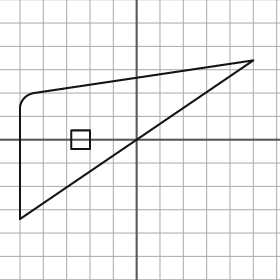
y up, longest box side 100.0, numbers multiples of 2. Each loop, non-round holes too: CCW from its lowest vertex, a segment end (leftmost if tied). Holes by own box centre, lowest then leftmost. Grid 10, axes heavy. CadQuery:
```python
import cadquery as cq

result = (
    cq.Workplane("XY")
    .moveTo(-50.0, -34.0)
    .lineTo(50.0, 34.0)
    .lineTo(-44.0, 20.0)
    .threePointArc((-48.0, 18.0), (-50.0, 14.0))
    .close()
    .moveTo(-28.0, -4.0)
    .lineTo(-20.0, -4.0)
    .lineTo(-20.0, 4.0)
    .lineTo(-28.0, 4.0)
    .close()
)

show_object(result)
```